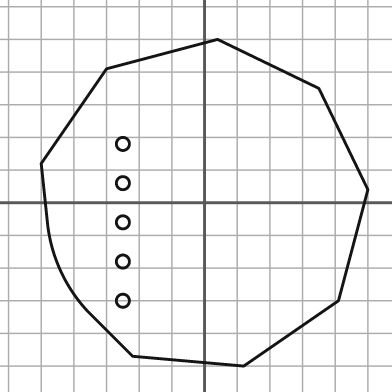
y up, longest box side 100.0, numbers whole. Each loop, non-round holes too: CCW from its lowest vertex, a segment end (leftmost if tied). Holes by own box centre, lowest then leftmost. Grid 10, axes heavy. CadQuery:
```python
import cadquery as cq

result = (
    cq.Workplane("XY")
    .moveTo(12.0, -50.0)
    .lineTo(41.0, -30.0)
    .lineTo(50.0, 4.0)
    .lineTo(35.0, 35.0)
    .lineTo(4.0, 50.0)
    .lineTo(-30.0, 41.0)
    .lineTo(-50.0, 12.0)
    .lineTo(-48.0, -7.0)
    .threePointArc((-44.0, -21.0), (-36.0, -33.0))
    .lineTo(-22.0, -47.0)
    .close()
    .moveTo(-25.0, -30.0)
    .circle(2.0)
    .moveTo(-25.0, -18.0)
    .circle(2.0)
    .moveTo(-25.0, -6.0)
    .circle(2.0)
    .moveTo(-25.0, 6.0)
    .circle(2.0)
    .moveTo(-25.0, 18.0)
    .circle(2.0)
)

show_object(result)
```